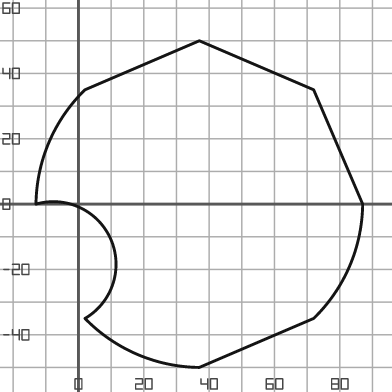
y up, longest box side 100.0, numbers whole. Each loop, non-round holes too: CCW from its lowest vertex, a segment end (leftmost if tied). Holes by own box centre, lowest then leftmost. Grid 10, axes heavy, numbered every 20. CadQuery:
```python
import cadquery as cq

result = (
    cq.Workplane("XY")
    .moveTo(37.0, -50.0)
    .lineTo(72.0, -35.0)
    .threePointArc((83.0, -19.0), (87.0, 0.0))
    .lineTo(72.0, 35.0)
    .lineTo(37.0, 50.0)
    .lineTo(2.0, 35.0)
    .threePointArc((-9.0, 19.0), (-13.0, 0.0))
    .threePointArc((10.0, -11.0), (2.0, -35.0))
    .threePointArc((18.0, -46.0), (37.0, -50.0))
    .close()
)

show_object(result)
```